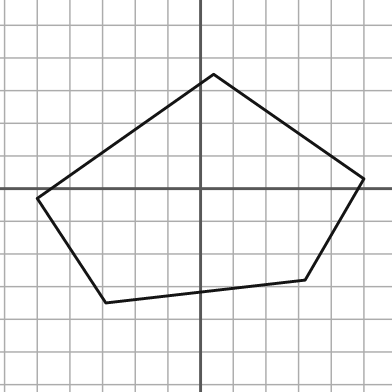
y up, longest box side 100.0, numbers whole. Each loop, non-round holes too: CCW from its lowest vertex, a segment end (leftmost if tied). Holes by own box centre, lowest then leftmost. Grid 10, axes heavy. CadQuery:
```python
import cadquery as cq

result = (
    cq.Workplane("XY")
    .moveTo(-29.0, -35.0)
    .lineTo(32.0, -28.0)
    .lineTo(50.0, 3.0)
    .lineTo(4.0, 35.0)
    .lineTo(-50.0, -3.0)
    .close()
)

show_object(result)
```